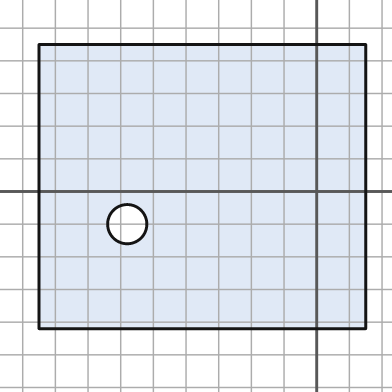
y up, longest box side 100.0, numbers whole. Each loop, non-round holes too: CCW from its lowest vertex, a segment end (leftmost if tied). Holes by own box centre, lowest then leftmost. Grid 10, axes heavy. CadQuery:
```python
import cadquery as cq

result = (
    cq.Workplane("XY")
    .moveTo(-85.0, -42.0)
    .lineTo(15.0, -42.0)
    .lineTo(15.0, 45.0)
    .lineTo(-85.0, 45.0)
    .close()
    .moveTo(-58.0, -10.0)
    .circle(6.0)
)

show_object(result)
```